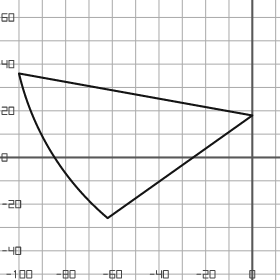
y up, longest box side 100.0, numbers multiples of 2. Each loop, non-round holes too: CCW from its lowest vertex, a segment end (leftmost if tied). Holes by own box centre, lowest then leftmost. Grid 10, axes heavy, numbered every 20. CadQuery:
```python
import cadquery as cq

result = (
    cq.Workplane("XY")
    .moveTo(-62.0, -26.0)
    .lineTo(0.0, 18.0)
    .lineTo(-100.0, 36.0)
    .threePointArc((-86.0, 2.0), (-62.0, -26.0))
    .close()
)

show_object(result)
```